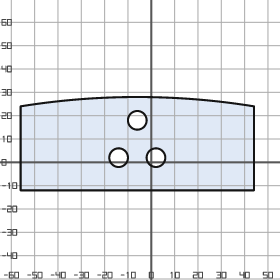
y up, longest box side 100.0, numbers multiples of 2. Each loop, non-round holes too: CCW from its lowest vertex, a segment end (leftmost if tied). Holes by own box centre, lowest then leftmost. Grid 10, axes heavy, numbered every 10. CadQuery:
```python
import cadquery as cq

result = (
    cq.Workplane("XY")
    .moveTo(-56.0, -12.0)
    .lineTo(44.0, -12.0)
    .lineTo(44.0, 24.0)
    .threePointArc((-6.0, 28.0), (-56.0, 24.0))
    .close()
    .moveTo(-14.0, 2.0)
    .circle(4.0)
    .moveTo(2.0, 2.0)
    .circle(4.0)
    .moveTo(-6.0, 18.0)
    .circle(4.0)
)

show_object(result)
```